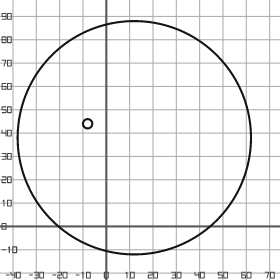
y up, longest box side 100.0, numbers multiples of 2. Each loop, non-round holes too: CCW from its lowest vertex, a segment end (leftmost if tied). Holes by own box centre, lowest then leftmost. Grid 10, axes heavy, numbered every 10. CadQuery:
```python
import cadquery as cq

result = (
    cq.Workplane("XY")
    .moveTo(12.0, 38.0)
    .circle(50.0)
    .moveTo(-8.0, 44.0)
    .circle(2.0)
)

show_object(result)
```